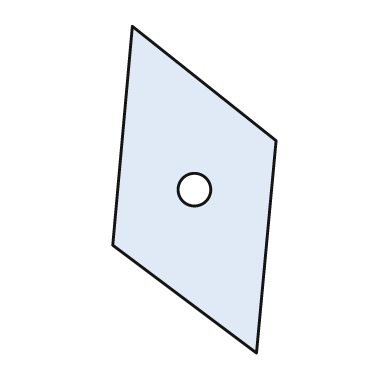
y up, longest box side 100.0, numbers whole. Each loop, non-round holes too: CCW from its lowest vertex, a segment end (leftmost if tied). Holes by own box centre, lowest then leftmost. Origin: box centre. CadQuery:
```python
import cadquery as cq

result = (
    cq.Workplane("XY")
    .moveTo(19.0, -50.0)
    .lineTo(25.0, 15.0)
    .lineTo(-19.0, 50.0)
    .lineTo(-25.0, -17.0)
    .close()
    .moveTo(0.0, 0.0)
    .circle(5.0)
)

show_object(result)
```